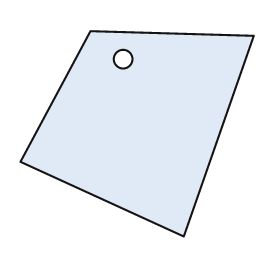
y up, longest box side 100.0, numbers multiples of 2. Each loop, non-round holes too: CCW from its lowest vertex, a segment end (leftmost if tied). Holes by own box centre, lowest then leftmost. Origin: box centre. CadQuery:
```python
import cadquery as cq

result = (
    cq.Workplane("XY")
    .moveTo(20.0, -44.0)
    .lineTo(50.0, 42.0)
    .lineTo(-20.0, 44.0)
    .lineTo(-50.0, -12.0)
    .close()
    .moveTo(-6.0, 32.0)
    .circle(4.0)
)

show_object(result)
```